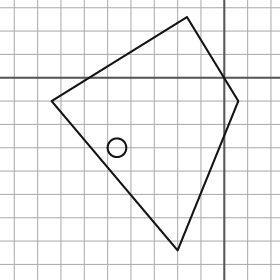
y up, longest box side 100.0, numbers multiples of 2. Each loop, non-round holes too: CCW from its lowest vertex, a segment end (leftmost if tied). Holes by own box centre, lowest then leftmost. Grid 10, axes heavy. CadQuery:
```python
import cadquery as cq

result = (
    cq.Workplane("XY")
    .moveTo(-20.0, -74.0)
    .lineTo(6.0, -10.0)
    .lineTo(-16.0, 26.0)
    .lineTo(-74.0, -10.0)
    .close()
    .moveTo(-46.0, -30.0)
    .circle(4.0)
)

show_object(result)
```